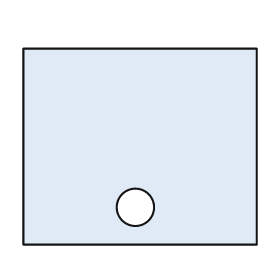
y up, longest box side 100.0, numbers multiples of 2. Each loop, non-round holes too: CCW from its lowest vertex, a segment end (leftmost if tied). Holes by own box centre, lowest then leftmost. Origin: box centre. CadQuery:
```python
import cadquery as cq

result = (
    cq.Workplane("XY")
    .moveTo(-50.0, -42.0)
    .lineTo(50.0, -42.0)
    .lineTo(50.0, 42.0)
    .lineTo(-50.0, 42.0)
    .close()
    .moveTo(-2.0, -26.0)
    .circle(8.0)
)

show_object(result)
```